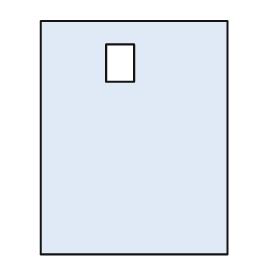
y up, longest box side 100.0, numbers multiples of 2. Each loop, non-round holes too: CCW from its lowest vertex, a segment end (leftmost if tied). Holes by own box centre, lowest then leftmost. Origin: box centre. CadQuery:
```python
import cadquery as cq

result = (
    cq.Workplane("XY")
    .moveTo(-40.0, -50.0)
    .lineTo(40.0, -50.0)
    .lineTo(40.0, 50.0)
    .lineTo(-40.0, 50.0)
    .close()
    .moveTo(-12.0, 24.0)
    .lineTo(0.0, 24.0)
    .lineTo(0.0, 40.0)
    .lineTo(-12.0, 40.0)
    .close()
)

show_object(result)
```